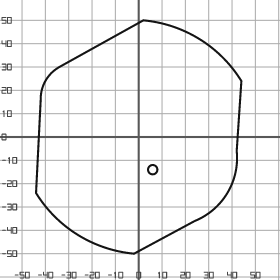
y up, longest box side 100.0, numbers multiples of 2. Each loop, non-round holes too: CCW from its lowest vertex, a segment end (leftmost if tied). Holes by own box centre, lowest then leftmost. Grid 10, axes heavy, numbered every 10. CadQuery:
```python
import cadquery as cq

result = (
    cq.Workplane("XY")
    .moveTo(-2.0, -50.0)
    .lineTo(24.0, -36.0)
    .threePointArc((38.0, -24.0), (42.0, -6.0))
    .lineTo(44.0, 24.0)
    .threePointArc((26.0, 42.0), (2.0, 50.0))
    .lineTo(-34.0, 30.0)
    .threePointArc((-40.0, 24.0), (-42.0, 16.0))
    .lineTo(-44.0, -24.0)
    .threePointArc((-26.0, -42.0), (-2.0, -50.0))
    .close()
    .moveTo(6.0, -14.0)
    .circle(2.0)
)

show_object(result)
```